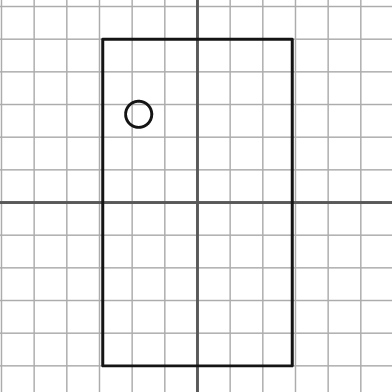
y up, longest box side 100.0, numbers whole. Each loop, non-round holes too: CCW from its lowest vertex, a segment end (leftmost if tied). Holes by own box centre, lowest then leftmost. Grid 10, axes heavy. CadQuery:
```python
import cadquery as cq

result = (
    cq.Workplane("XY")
    .moveTo(-29.0, -50.0)
    .lineTo(29.0, -50.0)
    .lineTo(29.0, 50.0)
    .lineTo(-29.0, 50.0)
    .close()
    .moveTo(-18.0, 27.0)
    .circle(4.0)
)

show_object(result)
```